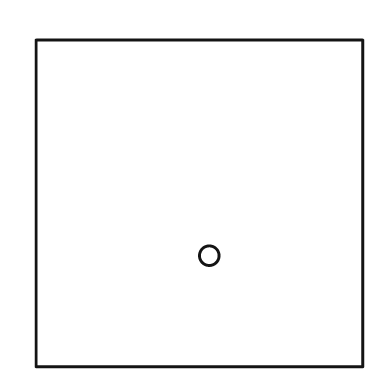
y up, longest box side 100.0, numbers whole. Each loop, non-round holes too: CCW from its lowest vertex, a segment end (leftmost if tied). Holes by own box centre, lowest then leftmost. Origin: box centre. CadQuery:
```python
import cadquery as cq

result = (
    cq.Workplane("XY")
    .moveTo(-50.0, -50.0)
    .lineTo(50.0, -50.0)
    .lineTo(50.0, 50.0)
    .lineTo(-50.0, 50.0)
    .close()
    .moveTo(3.0, -16.0)
    .circle(3.0)
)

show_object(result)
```